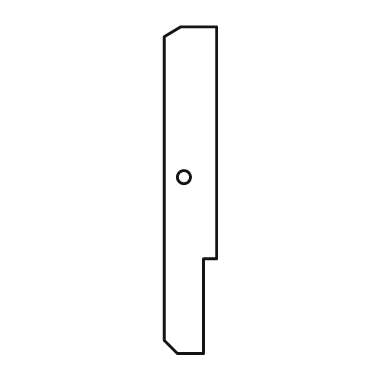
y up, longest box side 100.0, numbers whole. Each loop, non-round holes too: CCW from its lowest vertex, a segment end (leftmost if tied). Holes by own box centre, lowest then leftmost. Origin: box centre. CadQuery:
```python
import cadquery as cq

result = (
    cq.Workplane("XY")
    .moveTo(-4.0, -50.0)
    .lineTo(4.0, -50.0)
    .lineTo(4.0, -21.0)
    .lineTo(8.0, -21.0)
    .lineTo(8.0, 50.0)
    .lineTo(-3.0, 50.0)
    .lineTo(-8.0, 47.0)
    .lineTo(-8.0, -46.0)
    .close()
    .moveTo(-2.0, 4.0)
    .circle(2.0)
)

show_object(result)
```